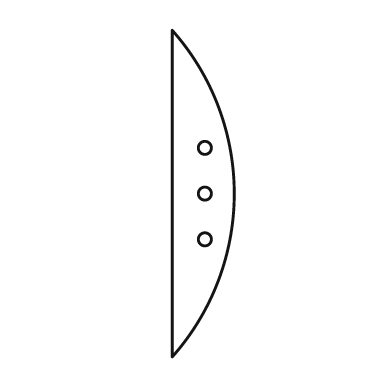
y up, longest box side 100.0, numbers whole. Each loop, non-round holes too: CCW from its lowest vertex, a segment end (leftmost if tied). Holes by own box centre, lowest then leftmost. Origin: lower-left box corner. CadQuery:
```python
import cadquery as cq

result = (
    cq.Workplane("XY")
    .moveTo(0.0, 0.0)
    .threePointArc((19.0, 50.0), (0.0, 100.0))
    .close()
    .moveTo(10.0, 36.0)
    .circle(2.0)
    .moveTo(10.0, 50.0)
    .circle(2.0)
    .moveTo(10.0, 64.0)
    .circle(2.0)
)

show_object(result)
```